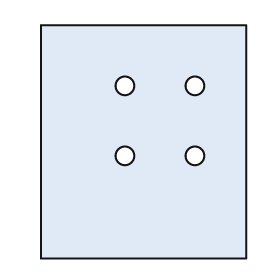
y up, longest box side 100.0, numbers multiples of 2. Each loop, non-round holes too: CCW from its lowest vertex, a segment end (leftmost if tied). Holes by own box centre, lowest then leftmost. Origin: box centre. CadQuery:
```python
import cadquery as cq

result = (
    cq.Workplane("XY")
    .moveTo(-44.0, -50.0)
    .lineTo(44.0, -50.0)
    .lineTo(44.0, 50.0)
    .lineTo(-44.0, 50.0)
    .close()
    .moveTo(-8.0, -6.0)
    .circle(4.0)
    .moveTo(22.0, -6.0)
    .circle(4.0)
    .moveTo(-8.0, 24.0)
    .circle(4.0)
    .moveTo(22.0, 24.0)
    .circle(4.0)
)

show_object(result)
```